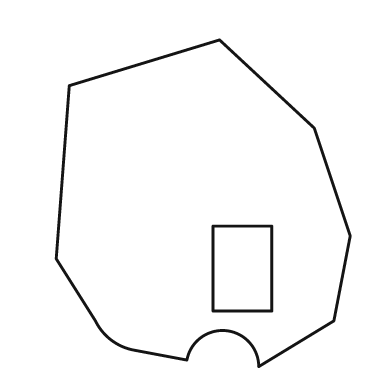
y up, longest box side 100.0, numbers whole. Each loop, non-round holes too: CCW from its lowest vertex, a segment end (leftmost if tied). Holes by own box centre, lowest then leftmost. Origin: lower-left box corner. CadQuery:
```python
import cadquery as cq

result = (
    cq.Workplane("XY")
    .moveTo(62.0, 0.0)
    .lineTo(85.0, 14.0)
    .lineTo(90.0, 40.0)
    .lineTo(79.0, 73.0)
    .lineTo(50.0, 100.0)
    .lineTo(4.0, 86.0)
    .lineTo(0.0, 33.0)
    .lineTo(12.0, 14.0)
    .threePointArc((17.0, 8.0), (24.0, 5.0))
    .lineTo(40.0, 2.0)
    .threePointArc((52.0, 11.0), (62.0, 0.0))
    .close()
    .moveTo(48.0, 17.0)
    .lineTo(66.0, 17.0)
    .lineTo(66.0, 43.0)
    .lineTo(48.0, 43.0)
    .close()
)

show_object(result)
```